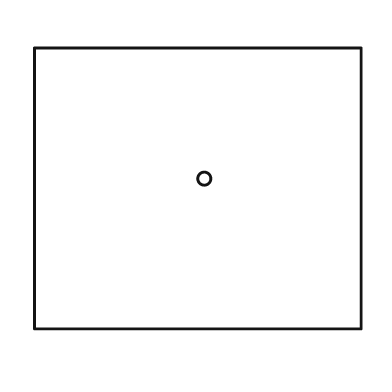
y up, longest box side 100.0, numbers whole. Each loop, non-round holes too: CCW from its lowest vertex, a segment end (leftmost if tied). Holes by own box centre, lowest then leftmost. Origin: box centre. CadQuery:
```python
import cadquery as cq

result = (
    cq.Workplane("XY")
    .moveTo(-50.0, -43.0)
    .lineTo(50.0, -43.0)
    .lineTo(50.0, 43.0)
    .lineTo(-50.0, 43.0)
    .close()
    .moveTo(2.0, 3.0)
    .circle(2.0)
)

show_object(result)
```